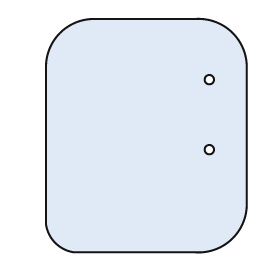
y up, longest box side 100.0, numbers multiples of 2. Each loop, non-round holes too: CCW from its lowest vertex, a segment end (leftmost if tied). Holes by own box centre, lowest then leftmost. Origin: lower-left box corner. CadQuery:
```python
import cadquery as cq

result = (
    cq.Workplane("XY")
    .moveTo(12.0, 0.0)
    .lineTo(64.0, 0.0)
    .threePointArc((80.0, 6.0), (86.0, 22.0))
    .lineTo(86.0, 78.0)
    .threePointArc((80.0, 94.0), (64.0, 100.0))
    .lineTo(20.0, 100.0)
    .threePointArc((6.0, 94.0), (0.0, 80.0))
    .lineTo(0.0, 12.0)
    .threePointArc((4.0, 4.0), (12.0, 0.0))
    .close()
    .moveTo(70.0, 44.0)
    .circle(2.0)
    .moveTo(70.0, 74.0)
    .circle(2.0)
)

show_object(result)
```